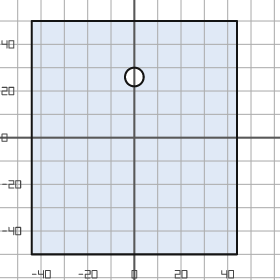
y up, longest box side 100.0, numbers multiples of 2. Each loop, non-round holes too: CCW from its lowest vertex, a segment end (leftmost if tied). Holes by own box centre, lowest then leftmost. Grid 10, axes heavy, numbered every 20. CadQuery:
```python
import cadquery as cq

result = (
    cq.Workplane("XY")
    .moveTo(-44.0, -50.0)
    .lineTo(44.0, -50.0)
    .lineTo(44.0, 50.0)
    .lineTo(-44.0, 50.0)
    .close()
    .moveTo(0.0, 26.0)
    .circle(4.0)
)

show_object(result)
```